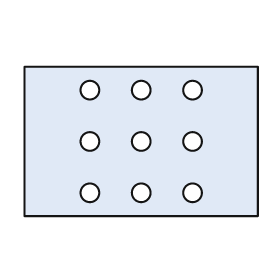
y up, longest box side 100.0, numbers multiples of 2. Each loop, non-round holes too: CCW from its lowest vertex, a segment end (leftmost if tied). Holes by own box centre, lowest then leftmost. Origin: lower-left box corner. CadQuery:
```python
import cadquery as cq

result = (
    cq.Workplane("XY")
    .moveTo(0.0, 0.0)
    .lineTo(100.0, 0.0)
    .lineTo(100.0, 64.0)
    .lineTo(0.0, 64.0)
    .close()
    .moveTo(28.0, 10.0)
    .circle(4.0)
    .moveTo(50.0, 10.0)
    .circle(4.0)
    .moveTo(72.0, 10.0)
    .circle(4.0)
    .moveTo(28.0, 32.0)
    .circle(4.0)
    .moveTo(50.0, 32.0)
    .circle(4.0)
    .moveTo(72.0, 32.0)
    .circle(4.0)
    .moveTo(28.0, 54.0)
    .circle(4.0)
    .moveTo(50.0, 54.0)
    .circle(4.0)
    .moveTo(72.0, 54.0)
    .circle(4.0)
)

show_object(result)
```